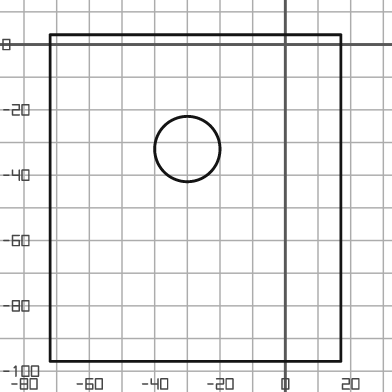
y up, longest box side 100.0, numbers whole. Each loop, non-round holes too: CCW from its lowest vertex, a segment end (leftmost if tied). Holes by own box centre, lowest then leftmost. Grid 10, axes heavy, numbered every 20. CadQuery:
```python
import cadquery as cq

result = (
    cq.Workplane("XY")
    .moveTo(-72.0, -97.0)
    .lineTo(17.0, -97.0)
    .lineTo(17.0, 3.0)
    .lineTo(-72.0, 3.0)
    .close()
    .moveTo(-30.0, -32.0)
    .circle(10.0)
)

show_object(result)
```